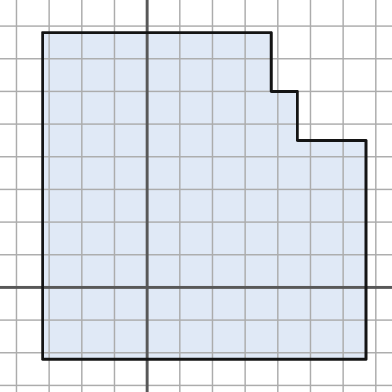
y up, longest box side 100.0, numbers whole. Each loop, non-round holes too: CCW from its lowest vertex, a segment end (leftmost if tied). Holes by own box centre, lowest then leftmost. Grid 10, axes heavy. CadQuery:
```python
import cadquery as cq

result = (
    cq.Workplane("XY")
    .moveTo(-32.0, -22.0)
    .lineTo(67.0, -22.0)
    .lineTo(67.0, 45.0)
    .lineTo(46.0, 45.0)
    .lineTo(46.0, 60.0)
    .lineTo(38.0, 60.0)
    .lineTo(38.0, 78.0)
    .lineTo(-32.0, 78.0)
    .close()
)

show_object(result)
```